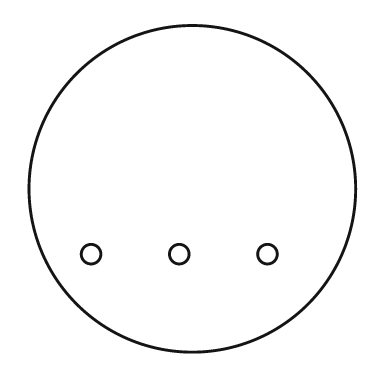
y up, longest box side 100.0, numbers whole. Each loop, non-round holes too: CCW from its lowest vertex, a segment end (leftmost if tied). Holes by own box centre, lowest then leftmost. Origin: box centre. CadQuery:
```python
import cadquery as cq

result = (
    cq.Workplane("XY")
    .moveTo(0.0, 0.0)
    .circle(50.0)
    .moveTo(-31.0, -20.0)
    .circle(3.0)
    .moveTo(-4.0, -20.0)
    .circle(3.0)
    .moveTo(23.0, -20.0)
    .circle(3.0)
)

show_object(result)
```